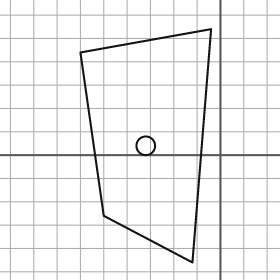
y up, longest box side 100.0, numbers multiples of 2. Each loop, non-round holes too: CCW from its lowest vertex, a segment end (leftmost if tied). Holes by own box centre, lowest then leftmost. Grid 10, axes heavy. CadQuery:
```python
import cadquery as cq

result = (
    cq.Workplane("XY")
    .moveTo(-12.0, -46.0)
    .lineTo(-4.0, 54.0)
    .lineTo(-60.0, 44.0)
    .lineTo(-50.0, -26.0)
    .close()
    .moveTo(-32.0, 4.0)
    .circle(4.0)
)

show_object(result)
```